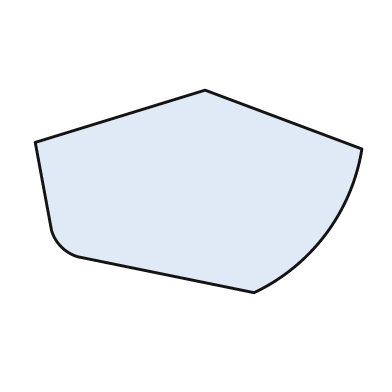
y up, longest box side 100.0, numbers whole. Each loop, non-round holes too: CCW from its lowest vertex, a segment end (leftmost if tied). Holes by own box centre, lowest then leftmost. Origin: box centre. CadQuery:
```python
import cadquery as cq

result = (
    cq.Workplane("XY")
    .moveTo(17.0, -31.0)
    .threePointArc((39.0, -13.0), (50.0, 13.0))
    .lineTo(2.0, 31.0)
    .lineTo(-50.0, 15.0)
    .lineTo(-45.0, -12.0)
    .threePointArc((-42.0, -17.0), (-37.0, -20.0))
    .close()
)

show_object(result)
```